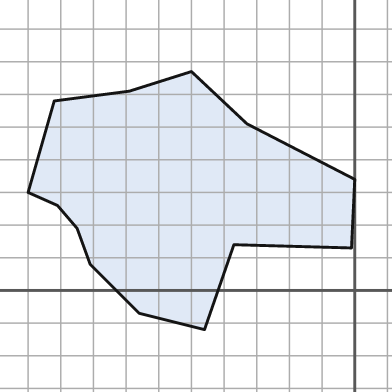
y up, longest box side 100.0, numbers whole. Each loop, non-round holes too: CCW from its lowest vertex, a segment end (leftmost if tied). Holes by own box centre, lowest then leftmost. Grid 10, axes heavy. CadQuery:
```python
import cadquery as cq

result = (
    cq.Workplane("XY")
    .moveTo(-46.0, -12.0)
    .lineTo(-37.0, 14.0)
    .lineTo(-1.0, 13.0)
    .lineTo(0.0, 34.0)
    .lineTo(-33.0, 51.0)
    .lineTo(-50.0, 67.0)
    .lineTo(-69.0, 61.0)
    .lineTo(-92.0, 58.0)
    .lineTo(-100.0, 30.0)
    .lineTo(-91.0, 26.0)
    .lineTo(-85.0, 19.0)
    .lineTo(-81.0, 8.0)
    .lineTo(-66.0, -7.0)
    .close()
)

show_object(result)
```